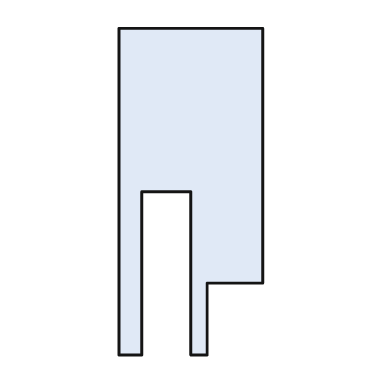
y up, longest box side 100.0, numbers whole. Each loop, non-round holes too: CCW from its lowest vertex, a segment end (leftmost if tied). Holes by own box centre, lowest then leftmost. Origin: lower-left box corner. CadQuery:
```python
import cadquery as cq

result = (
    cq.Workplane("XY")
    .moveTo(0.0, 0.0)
    .lineTo(7.0, 0.0)
    .lineTo(7.0, 50.0)
    .lineTo(22.0, 50.0)
    .lineTo(22.0, 0.0)
    .lineTo(27.0, 0.0)
    .lineTo(27.0, 22.0)
    .lineTo(44.0, 22.0)
    .lineTo(44.0, 100.0)
    .lineTo(0.0, 100.0)
    .close()
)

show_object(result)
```